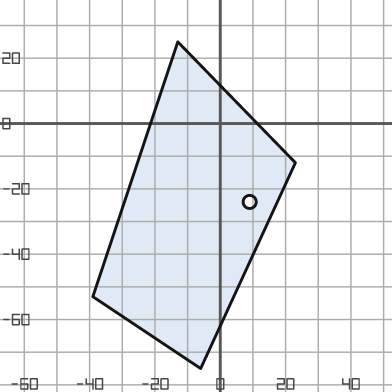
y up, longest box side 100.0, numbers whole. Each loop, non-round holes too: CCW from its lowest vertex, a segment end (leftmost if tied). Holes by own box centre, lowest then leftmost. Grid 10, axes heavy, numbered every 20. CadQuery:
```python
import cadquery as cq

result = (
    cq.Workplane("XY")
    .moveTo(-6.0, -75.0)
    .lineTo(23.0, -12.0)
    .lineTo(-13.0, 25.0)
    .lineTo(-39.0, -53.0)
    .close()
    .moveTo(9.0, -24.0)
    .circle(2.0)
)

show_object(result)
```